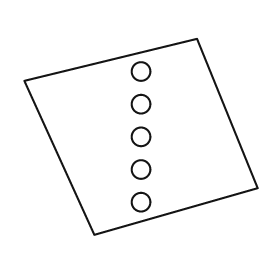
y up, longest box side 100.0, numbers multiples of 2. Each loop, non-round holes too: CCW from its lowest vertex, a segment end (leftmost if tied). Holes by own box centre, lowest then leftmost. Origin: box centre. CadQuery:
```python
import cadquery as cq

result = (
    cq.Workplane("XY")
    .moveTo(-20.0, -42.0)
    .lineTo(50.0, -22.0)
    .lineTo(24.0, 42.0)
    .lineTo(-50.0, 24.0)
    .close()
    .moveTo(0.0, -28.0)
    .circle(4.0)
    .moveTo(0.0, -14.0)
    .circle(4.0)
    .moveTo(0.0, 0.0)
    .circle(4.0)
    .moveTo(0.0, 14.0)
    .circle(4.0)
    .moveTo(0.0, 28.0)
    .circle(4.0)
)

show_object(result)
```